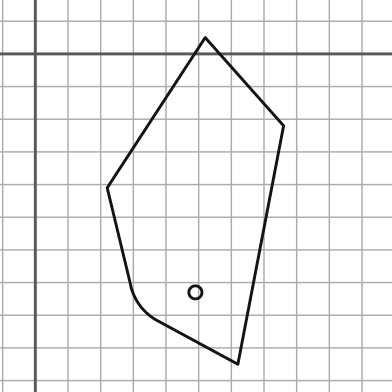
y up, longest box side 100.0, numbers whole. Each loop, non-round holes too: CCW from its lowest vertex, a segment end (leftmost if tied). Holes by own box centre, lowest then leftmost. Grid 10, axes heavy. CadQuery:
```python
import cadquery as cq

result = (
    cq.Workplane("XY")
    .moveTo(62.0, -95.0)
    .lineTo(76.0, -22.0)
    .lineTo(52.0, 5.0)
    .lineTo(22.0, -41.0)
    .lineTo(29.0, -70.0)
    .threePointArc((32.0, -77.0), (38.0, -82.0))
    .close()
    .moveTo(49.0, -73.0)
    .circle(2.0)
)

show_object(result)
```